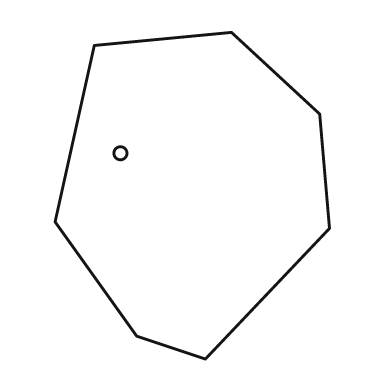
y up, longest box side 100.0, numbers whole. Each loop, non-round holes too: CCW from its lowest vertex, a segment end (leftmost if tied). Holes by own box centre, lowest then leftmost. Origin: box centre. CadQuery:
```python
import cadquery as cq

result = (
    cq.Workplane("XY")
    .moveTo(4.0, -50.0)
    .lineTo(42.0, -10.0)
    .lineTo(39.0, 25.0)
    .lineTo(12.0, 50.0)
    .lineTo(-30.0, 46.0)
    .lineTo(-42.0, -8.0)
    .lineTo(-17.0, -43.0)
    .close()
    .moveTo(-22.0, 13.0)
    .circle(2.0)
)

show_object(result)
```